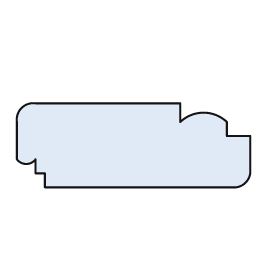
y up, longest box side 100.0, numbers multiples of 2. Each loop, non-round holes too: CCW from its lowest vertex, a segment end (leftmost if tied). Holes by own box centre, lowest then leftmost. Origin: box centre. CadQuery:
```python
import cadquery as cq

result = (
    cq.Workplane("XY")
    .moveTo(-38.0, -18.0)
    .lineTo(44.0, -18.0)
    .threePointArc((48.0, -16.0), (50.0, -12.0))
    .lineTo(50.0, 4.0)
    .lineTo(40.0, 4.0)
    .lineTo(40.0, 10.0)
    .threePointArc((30.0, 14.0), (20.0, 10.0))
    .lineTo(20.0, 18.0)
    .lineTo(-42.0, 18.0)
    .threePointArc((-48.0, 16.0), (-50.0, 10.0))
    .lineTo(-50.0, -6.0)
    .threePointArc((-46.0, -8.0), (-42.0, -6.0))
    .lineTo(-42.0, -12.0)
    .lineTo(-38.0, -12.0)
    .close()
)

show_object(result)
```